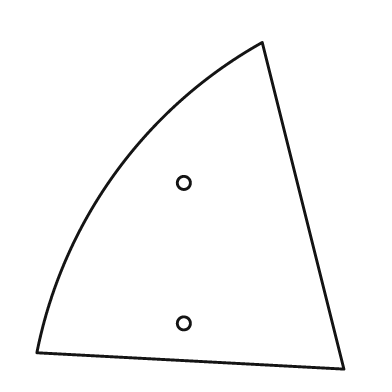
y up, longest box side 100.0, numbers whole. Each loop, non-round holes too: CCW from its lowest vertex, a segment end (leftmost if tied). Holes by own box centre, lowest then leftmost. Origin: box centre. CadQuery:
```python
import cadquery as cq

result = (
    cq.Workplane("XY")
    .moveTo(47.0, -50.0)
    .lineTo(22.0, 50.0)
    .threePointArc((-23.0, 10.0), (-47.0, -45.0))
    .close()
    .moveTo(-2.0, -36.0)
    .circle(2.0)
    .moveTo(-2.0, 7.0)
    .circle(2.0)
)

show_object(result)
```